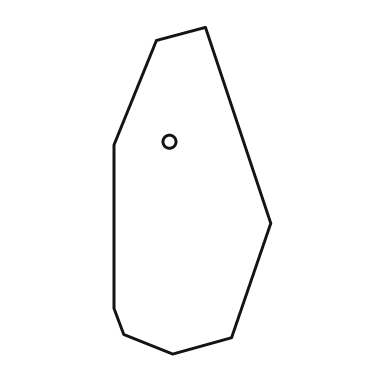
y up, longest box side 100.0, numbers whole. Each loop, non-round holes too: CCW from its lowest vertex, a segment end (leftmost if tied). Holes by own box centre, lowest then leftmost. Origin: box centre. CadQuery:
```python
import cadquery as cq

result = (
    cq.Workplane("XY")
    .moveTo(-6.0, -50.0)
    .lineTo(12.0, -45.0)
    .lineTo(24.0, -10.0)
    .lineTo(4.0, 50.0)
    .lineTo(-11.0, 46.0)
    .lineTo(-24.0, 14.0)
    .lineTo(-24.0, -36.0)
    .lineTo(-21.0, -44.0)
    .close()
    .moveTo(-7.0, 15.0)
    .circle(2.0)
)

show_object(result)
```